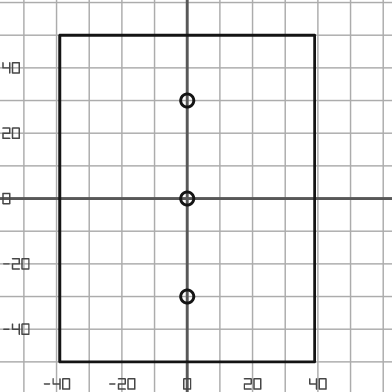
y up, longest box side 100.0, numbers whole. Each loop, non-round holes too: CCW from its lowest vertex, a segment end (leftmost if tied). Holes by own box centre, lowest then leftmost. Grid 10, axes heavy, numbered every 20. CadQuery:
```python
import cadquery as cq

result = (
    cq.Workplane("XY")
    .moveTo(-39.0, -50.0)
    .lineTo(39.0, -50.0)
    .lineTo(39.0, 50.0)
    .lineTo(-39.0, 50.0)
    .close()
    .moveTo(0.0, -30.0)
    .circle(2.0)
    .moveTo(0.0, 0.0)
    .circle(2.0)
    .moveTo(0.0, 30.0)
    .circle(2.0)
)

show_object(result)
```